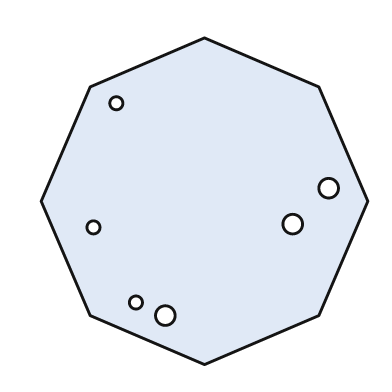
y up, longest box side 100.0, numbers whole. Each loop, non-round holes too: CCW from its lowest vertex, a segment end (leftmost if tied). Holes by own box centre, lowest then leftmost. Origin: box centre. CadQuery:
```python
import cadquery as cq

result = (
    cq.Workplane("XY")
    .moveTo(0.0, -50.0)
    .lineTo(35.0, -35.0)
    .lineTo(50.0, 0.0)
    .lineTo(35.0, 35.0)
    .lineTo(0.0, 50.0)
    .lineTo(-35.0, 35.0)
    .lineTo(-50.0, 0.0)
    .lineTo(-35.0, -35.0)
    .close()
    .moveTo(-12.0, -35.0)
    .circle(3.0)
    .moveTo(-21.0, -31.0)
    .circle(2.0)
    .moveTo(-34.0, -8.0)
    .circle(2.0)
    .moveTo(27.0, -7.0)
    .circle(3.0)
    .moveTo(38.0, 4.0)
    .circle(3.0)
    .moveTo(-27.0, 30.0)
    .circle(2.0)
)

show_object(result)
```